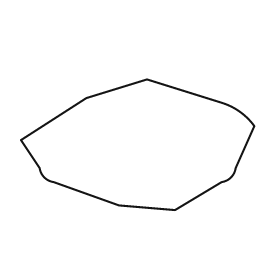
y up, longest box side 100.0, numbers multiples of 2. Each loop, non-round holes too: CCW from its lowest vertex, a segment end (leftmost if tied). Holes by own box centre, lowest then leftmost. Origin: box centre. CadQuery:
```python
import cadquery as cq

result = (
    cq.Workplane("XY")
    .moveTo(16.0, -28.0)
    .lineTo(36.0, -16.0)
    .threePointArc((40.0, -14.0), (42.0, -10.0))
    .lineTo(50.0, 8.0)
    .threePointArc((44.0, 14.0), (36.0, 18.0))
    .lineTo(4.0, 28.0)
    .lineTo(-22.0, 20.0)
    .lineTo(-50.0, 2.0)
    .lineTo(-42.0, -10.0)
    .threePointArc((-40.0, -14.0), (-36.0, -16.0))
    .lineTo(-8.0, -26.0)
    .close()
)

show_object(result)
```